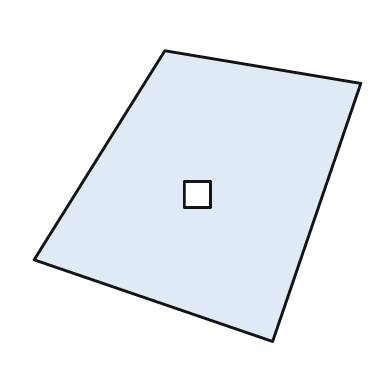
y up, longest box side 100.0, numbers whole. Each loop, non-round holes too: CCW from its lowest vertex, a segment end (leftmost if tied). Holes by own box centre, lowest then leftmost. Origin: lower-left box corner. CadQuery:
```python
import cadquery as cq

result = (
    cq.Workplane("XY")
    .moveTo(73.0, 0.0)
    .lineTo(100.0, 79.0)
    .lineTo(40.0, 89.0)
    .lineTo(0.0, 25.0)
    .close()
    .moveTo(46.0, 41.0)
    .lineTo(54.0, 41.0)
    .lineTo(54.0, 49.0)
    .lineTo(46.0, 49.0)
    .close()
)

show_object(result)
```